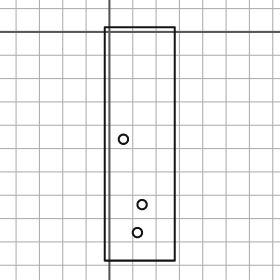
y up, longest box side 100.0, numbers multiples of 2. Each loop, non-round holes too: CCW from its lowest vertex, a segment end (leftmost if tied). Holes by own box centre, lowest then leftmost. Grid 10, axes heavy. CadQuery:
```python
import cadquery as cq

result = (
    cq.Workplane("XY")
    .moveTo(-2.0, -98.0)
    .lineTo(28.0, -98.0)
    .lineTo(28.0, 2.0)
    .lineTo(-2.0, 2.0)
    .close()
    .moveTo(12.0, -86.0)
    .circle(2.0)
    .moveTo(14.0, -74.0)
    .circle(2.0)
    .moveTo(6.0, -46.0)
    .circle(2.0)
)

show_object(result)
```